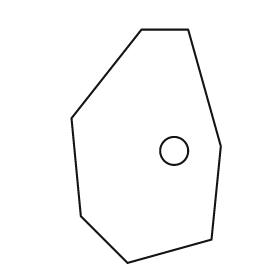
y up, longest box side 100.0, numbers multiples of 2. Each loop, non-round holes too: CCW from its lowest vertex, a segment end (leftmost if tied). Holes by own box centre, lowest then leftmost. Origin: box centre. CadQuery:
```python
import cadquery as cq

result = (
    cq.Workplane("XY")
    .moveTo(-8.0, -50.0)
    .lineTo(28.0, -40.0)
    .lineTo(32.0, 0.0)
    .lineTo(18.0, 50.0)
    .lineTo(-2.0, 50.0)
    .lineTo(-32.0, 12.0)
    .lineTo(-28.0, -30.0)
    .close()
    .moveTo(12.0, -2.0)
    .circle(6.0)
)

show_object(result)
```